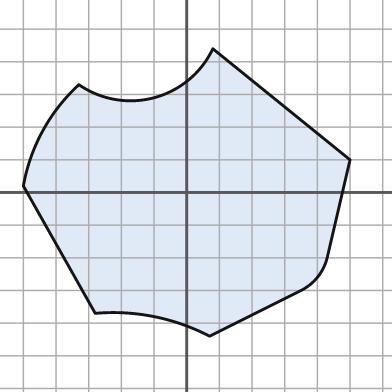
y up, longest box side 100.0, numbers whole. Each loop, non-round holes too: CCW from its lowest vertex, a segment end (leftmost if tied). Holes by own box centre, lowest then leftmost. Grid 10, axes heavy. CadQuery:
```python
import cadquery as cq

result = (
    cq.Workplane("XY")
    .moveTo(7.0, -44.0)
    .lineTo(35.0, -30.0)
    .threePointArc((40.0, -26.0), (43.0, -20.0))
    .lineTo(50.0, 10.0)
    .lineTo(8.0, 44.0)
    .threePointArc((-10.0, 29.0), (-33.0, 33.0))
    .threePointArc((-44.0, 19.0), (-50.0, 2.0))
    .lineTo(-28.0, -37.0)
    .threePointArc((-10.0, -38.0), (7.0, -44.0))
    .close()
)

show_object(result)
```